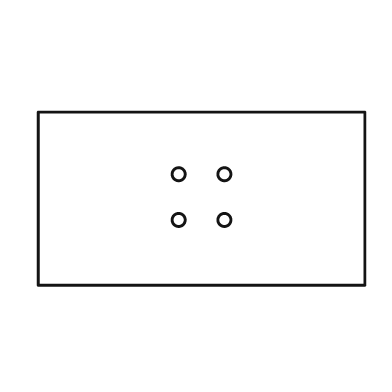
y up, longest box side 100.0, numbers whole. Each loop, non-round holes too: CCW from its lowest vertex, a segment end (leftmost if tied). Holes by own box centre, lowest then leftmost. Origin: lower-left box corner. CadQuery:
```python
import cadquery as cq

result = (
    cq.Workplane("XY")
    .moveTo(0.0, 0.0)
    .lineTo(100.0, 0.0)
    .lineTo(100.0, 53.0)
    .lineTo(0.0, 53.0)
    .close()
    .moveTo(43.0, 20.0)
    .circle(2.0)
    .moveTo(57.0, 20.0)
    .circle(2.0)
    .moveTo(43.0, 34.0)
    .circle(2.0)
    .moveTo(57.0, 34.0)
    .circle(2.0)
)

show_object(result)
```